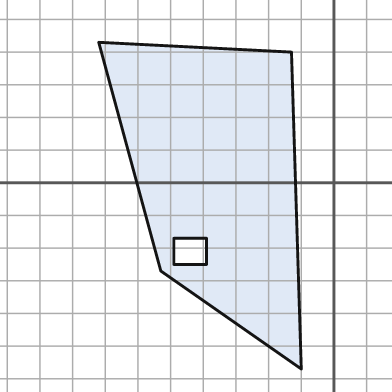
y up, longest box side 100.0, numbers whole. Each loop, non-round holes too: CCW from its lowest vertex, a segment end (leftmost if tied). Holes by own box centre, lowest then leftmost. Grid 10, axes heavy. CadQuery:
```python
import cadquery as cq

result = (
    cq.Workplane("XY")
    .moveTo(-10.0, -57.0)
    .lineTo(-13.0, 40.0)
    .lineTo(-72.0, 43.0)
    .lineTo(-53.0, -27.0)
    .close()
    .moveTo(-49.0, -25.0)
    .lineTo(-39.0, -25.0)
    .lineTo(-39.0, -17.0)
    .lineTo(-49.0, -17.0)
    .close()
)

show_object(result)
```